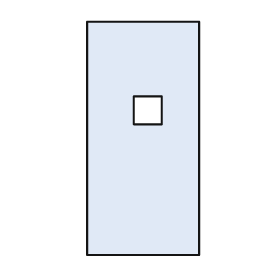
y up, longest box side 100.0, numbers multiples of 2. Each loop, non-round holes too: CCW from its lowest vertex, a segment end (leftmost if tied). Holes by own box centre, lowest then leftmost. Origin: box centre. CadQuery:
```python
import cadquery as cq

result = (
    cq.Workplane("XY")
    .moveTo(-24.0, -50.0)
    .lineTo(24.0, -50.0)
    .lineTo(24.0, 50.0)
    .lineTo(-24.0, 50.0)
    .close()
    .moveTo(-4.0, 6.0)
    .lineTo(8.0, 6.0)
    .lineTo(8.0, 18.0)
    .lineTo(-4.0, 18.0)
    .close()
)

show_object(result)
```